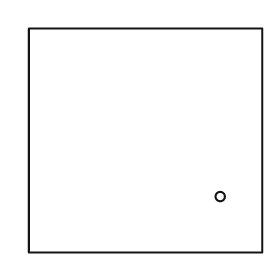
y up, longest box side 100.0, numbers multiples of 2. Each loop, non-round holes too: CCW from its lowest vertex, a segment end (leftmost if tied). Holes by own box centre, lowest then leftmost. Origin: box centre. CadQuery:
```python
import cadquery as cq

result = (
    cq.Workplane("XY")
    .moveTo(-50.0, -48.0)
    .lineTo(50.0, -48.0)
    .lineTo(50.0, 48.0)
    .lineTo(-50.0, 48.0)
    .close()
    .moveTo(32.0, -24.0)
    .circle(2.0)
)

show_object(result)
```